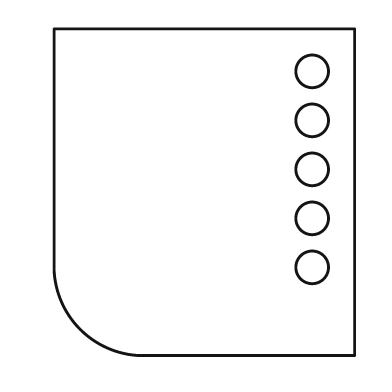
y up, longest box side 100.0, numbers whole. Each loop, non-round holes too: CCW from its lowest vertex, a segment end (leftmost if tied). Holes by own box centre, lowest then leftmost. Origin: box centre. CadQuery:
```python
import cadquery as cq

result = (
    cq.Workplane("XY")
    .moveTo(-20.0, -50.0)
    .lineTo(46.0, -50.0)
    .lineTo(46.0, 50.0)
    .lineTo(-46.0, 50.0)
    .lineTo(-46.0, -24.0)
    .threePointArc((-38.0, -42.0), (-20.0, -50.0))
    .close()
    .moveTo(33.0, -23.0)
    .circle(5.0)
    .moveTo(33.0, -8.0)
    .circle(5.0)
    .moveTo(33.0, 7.0)
    .circle(5.0)
    .moveTo(33.0, 22.0)
    .circle(5.0)
    .moveTo(33.0, 37.0)
    .circle(5.0)
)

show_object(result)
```